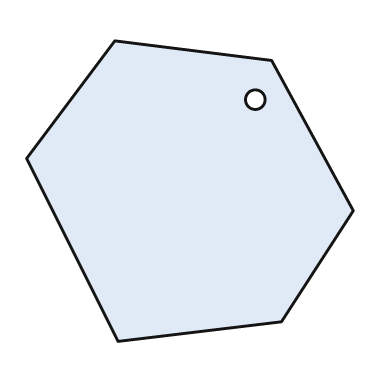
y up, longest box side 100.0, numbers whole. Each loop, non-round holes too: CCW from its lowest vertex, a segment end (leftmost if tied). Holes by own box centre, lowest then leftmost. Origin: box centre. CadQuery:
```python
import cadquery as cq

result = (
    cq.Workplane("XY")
    .moveTo(-22.0, -46.0)
    .lineTo(28.0, -40.0)
    .lineTo(50.0, -6.0)
    .lineTo(25.0, 40.0)
    .lineTo(-23.0, 46.0)
    .lineTo(-50.0, 10.0)
    .close()
    .moveTo(20.0, 28.0)
    .circle(3.0)
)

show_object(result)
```